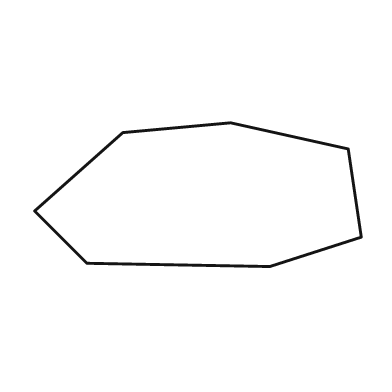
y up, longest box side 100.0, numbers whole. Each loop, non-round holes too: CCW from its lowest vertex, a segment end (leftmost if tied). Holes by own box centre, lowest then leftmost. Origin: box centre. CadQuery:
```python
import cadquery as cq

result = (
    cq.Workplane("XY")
    .moveTo(22.0, -22.0)
    .lineTo(50.0, -13.0)
    .lineTo(46.0, 14.0)
    .lineTo(10.0, 22.0)
    .lineTo(-23.0, 19.0)
    .lineTo(-50.0, -5.0)
    .lineTo(-34.0, -21.0)
    .close()
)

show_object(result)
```